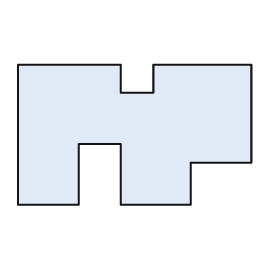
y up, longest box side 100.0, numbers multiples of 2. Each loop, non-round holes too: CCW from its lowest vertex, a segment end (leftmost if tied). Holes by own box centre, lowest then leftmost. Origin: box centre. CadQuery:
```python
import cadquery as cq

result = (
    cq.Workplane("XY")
    .moveTo(-50.0, -30.0)
    .lineTo(-24.0, -30.0)
    .lineTo(-24.0, -4.0)
    .lineTo(-6.0, -4.0)
    .lineTo(-6.0, -30.0)
    .lineTo(24.0, -30.0)
    .lineTo(24.0, -12.0)
    .lineTo(50.0, -12.0)
    .lineTo(50.0, 30.0)
    .lineTo(8.0, 30.0)
    .lineTo(8.0, 18.0)
    .lineTo(-6.0, 18.0)
    .lineTo(-6.0, 30.0)
    .lineTo(-50.0, 30.0)
    .close()
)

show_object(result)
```